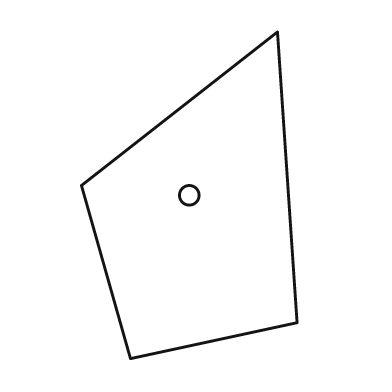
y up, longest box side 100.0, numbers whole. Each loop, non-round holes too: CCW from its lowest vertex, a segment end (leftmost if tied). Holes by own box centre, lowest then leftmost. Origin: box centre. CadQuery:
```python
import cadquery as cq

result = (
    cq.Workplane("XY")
    .moveTo(-18.0, -50.0)
    .lineTo(33.0, -39.0)
    .lineTo(27.0, 50.0)
    .lineTo(-33.0, 3.0)
    .close()
    .moveTo(0.0, 0.0)
    .circle(3.0)
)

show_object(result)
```